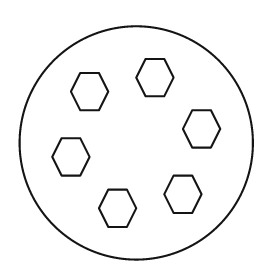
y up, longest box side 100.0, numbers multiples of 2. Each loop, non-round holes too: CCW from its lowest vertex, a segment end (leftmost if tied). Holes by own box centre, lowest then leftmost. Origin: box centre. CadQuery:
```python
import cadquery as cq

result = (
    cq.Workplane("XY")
    .moveTo(0.0, 0.0)
    .circle(50.0)
    .moveTo(-12.0, -36.0)
    .lineTo(-4.0, -36.0)
    .lineTo(0.0, -28.0)
    .lineTo(-4.0, -20.0)
    .lineTo(-12.0, -20.0)
    .lineTo(-16.0, -28.0)
    .close()
    .moveTo(16.0, -30.0)
    .lineTo(24.0, -30.0)
    .lineTo(28.0, -22.0)
    .lineTo(24.0, -14.0)
    .lineTo(16.0, -14.0)
    .lineTo(12.0, -22.0)
    .close()
    .moveTo(-32.0, -14.0)
    .lineTo(-24.0, -14.0)
    .lineTo(-20.0, -6.0)
    .lineTo(-24.0, 2.0)
    .lineTo(-32.0, 2.0)
    .lineTo(-36.0, -6.0)
    .close()
    .moveTo(24.0, -2.0)
    .lineTo(32.0, -2.0)
    .lineTo(36.0, 6.0)
    .lineTo(32.0, 14.0)
    .lineTo(24.0, 14.0)
    .lineTo(20.0, 6.0)
    .close()
    .moveTo(-24.0, 14.0)
    .lineTo(-16.0, 14.0)
    .lineTo(-12.0, 22.0)
    .lineTo(-16.0, 30.0)
    .lineTo(-24.0, 30.0)
    .lineTo(-28.0, 22.0)
    .close()
    .moveTo(4.0, 20.0)
    .lineTo(12.0, 20.0)
    .lineTo(16.0, 28.0)
    .lineTo(12.0, 36.0)
    .lineTo(4.0, 36.0)
    .lineTo(0.0, 28.0)
    .close()
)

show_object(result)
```